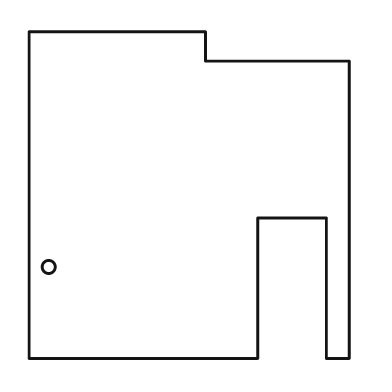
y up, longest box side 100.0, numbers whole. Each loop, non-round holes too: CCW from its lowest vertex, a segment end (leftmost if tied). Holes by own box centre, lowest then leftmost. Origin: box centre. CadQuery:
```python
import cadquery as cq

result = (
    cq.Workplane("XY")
    .moveTo(-49.0, -50.0)
    .lineTo(21.0, -50.0)
    .lineTo(21.0, -7.0)
    .lineTo(42.0, -7.0)
    .lineTo(42.0, -50.0)
    .lineTo(49.0, -50.0)
    .lineTo(49.0, 41.0)
    .lineTo(5.0, 41.0)
    .lineTo(5.0, 50.0)
    .lineTo(-49.0, 50.0)
    .close()
    .moveTo(-43.0, -22.0)
    .circle(2.0)
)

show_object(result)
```